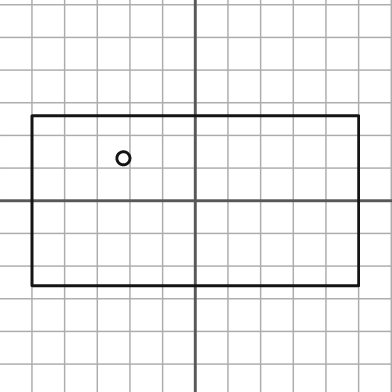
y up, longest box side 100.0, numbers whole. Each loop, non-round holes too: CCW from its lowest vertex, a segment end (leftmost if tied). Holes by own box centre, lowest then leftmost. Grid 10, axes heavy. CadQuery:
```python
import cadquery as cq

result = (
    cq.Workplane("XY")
    .moveTo(-50.0, -26.0)
    .lineTo(50.0, -26.0)
    .lineTo(50.0, 26.0)
    .lineTo(-50.0, 26.0)
    .close()
    .moveTo(-22.0, 13.0)
    .circle(2.0)
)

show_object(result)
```